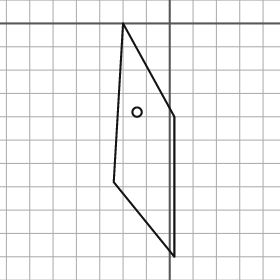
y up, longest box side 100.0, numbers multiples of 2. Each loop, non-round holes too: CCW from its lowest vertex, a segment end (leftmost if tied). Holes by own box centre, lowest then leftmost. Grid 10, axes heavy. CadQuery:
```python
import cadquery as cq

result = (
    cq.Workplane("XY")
    .moveTo(2.0, -100.0)
    .lineTo(2.0, -40.0)
    .lineTo(-20.0, 0.0)
    .lineTo(-24.0, -68.0)
    .close()
    .moveTo(-14.0, -38.0)
    .circle(2.0)
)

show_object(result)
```